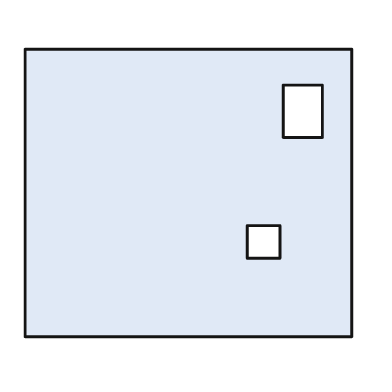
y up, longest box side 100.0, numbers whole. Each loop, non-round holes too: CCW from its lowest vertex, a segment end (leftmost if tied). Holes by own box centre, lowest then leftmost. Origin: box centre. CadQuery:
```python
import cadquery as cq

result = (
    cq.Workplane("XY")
    .moveTo(-50.0, -44.0)
    .lineTo(50.0, -44.0)
    .lineTo(50.0, 44.0)
    .lineTo(-50.0, 44.0)
    .close()
    .moveTo(18.0, -20.0)
    .lineTo(28.0, -20.0)
    .lineTo(28.0, -10.0)
    .lineTo(18.0, -10.0)
    .close()
    .moveTo(29.0, 17.0)
    .lineTo(41.0, 17.0)
    .lineTo(41.0, 33.0)
    .lineTo(29.0, 33.0)
    .close()
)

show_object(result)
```